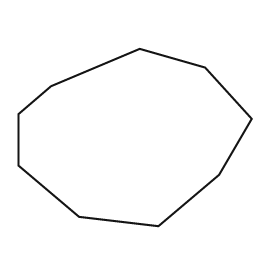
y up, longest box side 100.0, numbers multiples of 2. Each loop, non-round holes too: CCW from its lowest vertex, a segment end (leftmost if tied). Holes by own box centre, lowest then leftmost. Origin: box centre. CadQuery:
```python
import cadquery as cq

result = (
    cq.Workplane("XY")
    .moveTo(10.0, -38.0)
    .lineTo(36.0, -16.0)
    .lineTo(50.0, 8.0)
    .lineTo(30.0, 30.0)
    .lineTo(2.0, 38.0)
    .lineTo(-36.0, 22.0)
    .lineTo(-50.0, 10.0)
    .lineTo(-50.0, -12.0)
    .lineTo(-24.0, -34.0)
    .close()
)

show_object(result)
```